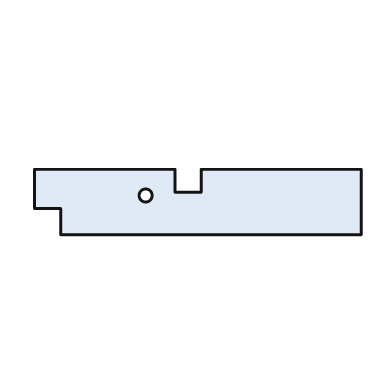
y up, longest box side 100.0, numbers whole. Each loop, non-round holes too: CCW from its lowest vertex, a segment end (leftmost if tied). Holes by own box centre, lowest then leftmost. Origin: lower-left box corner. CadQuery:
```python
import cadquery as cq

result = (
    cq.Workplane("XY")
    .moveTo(8.0, 0.0)
    .lineTo(100.0, 0.0)
    .lineTo(100.0, 20.0)
    .lineTo(51.0, 20.0)
    .lineTo(51.0, 13.0)
    .lineTo(43.0, 13.0)
    .lineTo(43.0, 20.0)
    .lineTo(0.0, 20.0)
    .lineTo(0.0, 8.0)
    .lineTo(8.0, 8.0)
    .close()
    .moveTo(34.0, 12.0)
    .circle(2.0)
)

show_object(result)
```